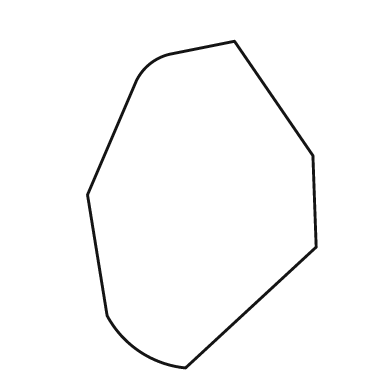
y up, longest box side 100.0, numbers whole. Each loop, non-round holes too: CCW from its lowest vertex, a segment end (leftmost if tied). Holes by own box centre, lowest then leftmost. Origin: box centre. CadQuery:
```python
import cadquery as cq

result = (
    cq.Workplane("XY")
    .moveTo(-5.0, -50.0)
    .lineTo(35.0, -13.0)
    .lineTo(34.0, 15.0)
    .lineTo(10.0, 50.0)
    .lineTo(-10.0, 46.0)
    .threePointArc((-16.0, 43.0), (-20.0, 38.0))
    .lineTo(-35.0, 3.0)
    .lineTo(-29.0, -34.0)
    .threePointArc((-19.0, -45.0), (-5.0, -50.0))
    .close()
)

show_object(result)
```